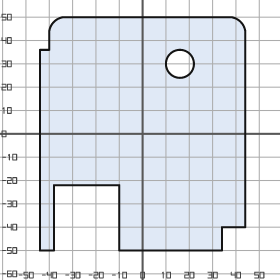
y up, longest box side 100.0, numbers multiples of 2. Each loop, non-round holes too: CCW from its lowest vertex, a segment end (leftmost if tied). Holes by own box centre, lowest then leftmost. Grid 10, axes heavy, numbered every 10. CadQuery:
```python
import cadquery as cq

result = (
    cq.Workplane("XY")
    .moveTo(-44.0, -50.0)
    .lineTo(-38.0, -50.0)
    .lineTo(-38.0, -22.0)
    .lineTo(-10.0, -22.0)
    .lineTo(-10.0, -50.0)
    .lineTo(34.0, -50.0)
    .lineTo(34.0, -40.0)
    .lineTo(44.0, -40.0)
    .lineTo(44.0, 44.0)
    .threePointArc((42.0, 48.0), (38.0, 50.0))
    .lineTo(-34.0, 50.0)
    .threePointArc((-38.0, 48.0), (-40.0, 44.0))
    .lineTo(-40.0, 36.0)
    .lineTo(-44.0, 36.0)
    .close()
    .moveTo(16.0, 30.0)
    .circle(6.0)
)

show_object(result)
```